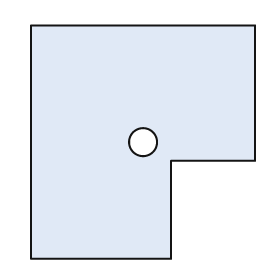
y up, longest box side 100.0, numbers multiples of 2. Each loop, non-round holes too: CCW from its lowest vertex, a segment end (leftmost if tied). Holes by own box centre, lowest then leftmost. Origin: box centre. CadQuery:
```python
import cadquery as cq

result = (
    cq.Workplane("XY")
    .moveTo(-48.0, -50.0)
    .lineTo(12.0, -50.0)
    .lineTo(12.0, -8.0)
    .lineTo(48.0, -8.0)
    .lineTo(48.0, 50.0)
    .lineTo(-48.0, 50.0)
    .close()
    .moveTo(0.0, 0.0)
    .circle(6.0)
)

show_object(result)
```